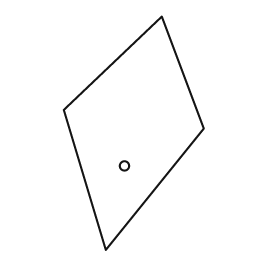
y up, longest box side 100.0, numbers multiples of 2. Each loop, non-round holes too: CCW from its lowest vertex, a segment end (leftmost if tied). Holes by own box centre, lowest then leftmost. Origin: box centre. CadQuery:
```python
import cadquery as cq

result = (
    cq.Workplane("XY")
    .moveTo(-12.0, -50.0)
    .lineTo(30.0, 2.0)
    .lineTo(12.0, 50.0)
    .lineTo(-30.0, 10.0)
    .close()
    .moveTo(-4.0, -14.0)
    .circle(2.0)
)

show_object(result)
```